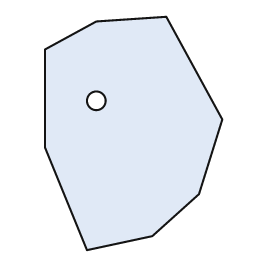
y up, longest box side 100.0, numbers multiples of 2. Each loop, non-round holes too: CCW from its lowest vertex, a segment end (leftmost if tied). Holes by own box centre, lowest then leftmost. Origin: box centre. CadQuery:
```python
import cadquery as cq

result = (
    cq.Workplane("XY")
    .moveTo(-20.0, -50.0)
    .lineTo(8.0, -44.0)
    .lineTo(28.0, -26.0)
    .lineTo(38.0, 6.0)
    .lineTo(14.0, 50.0)
    .lineTo(-16.0, 48.0)
    .lineTo(-38.0, 36.0)
    .lineTo(-38.0, -6.0)
    .close()
    .moveTo(-16.0, 14.0)
    .circle(4.0)
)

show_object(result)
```